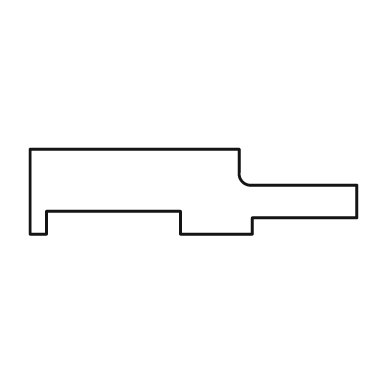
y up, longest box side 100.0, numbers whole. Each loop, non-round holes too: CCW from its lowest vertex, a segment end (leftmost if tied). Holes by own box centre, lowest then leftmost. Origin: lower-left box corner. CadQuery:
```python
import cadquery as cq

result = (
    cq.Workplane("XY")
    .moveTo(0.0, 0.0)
    .lineTo(5.0, 0.0)
    .lineTo(5.0, 7.0)
    .lineTo(46.0, 7.0)
    .lineTo(46.0, 0.0)
    .lineTo(68.0, 0.0)
    .lineTo(68.0, 5.0)
    .lineTo(100.0, 5.0)
    .lineTo(100.0, 15.0)
    .lineTo(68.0, 15.0)
    .threePointArc((65.0, 16.0), (64.0, 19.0))
    .lineTo(64.0, 26.0)
    .lineTo(0.0, 26.0)
    .close()
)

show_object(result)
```